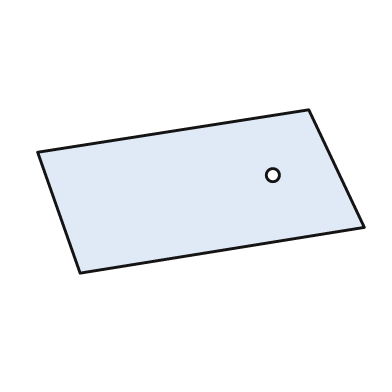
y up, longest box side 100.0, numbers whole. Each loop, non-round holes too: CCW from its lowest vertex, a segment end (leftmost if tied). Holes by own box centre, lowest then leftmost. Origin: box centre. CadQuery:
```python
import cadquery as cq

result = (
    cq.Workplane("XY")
    .moveTo(-37.0, -25.0)
    .lineTo(50.0, -11.0)
    .lineTo(33.0, 25.0)
    .lineTo(-50.0, 12.0)
    .close()
    .moveTo(22.0, 5.0)
    .circle(2.0)
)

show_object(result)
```